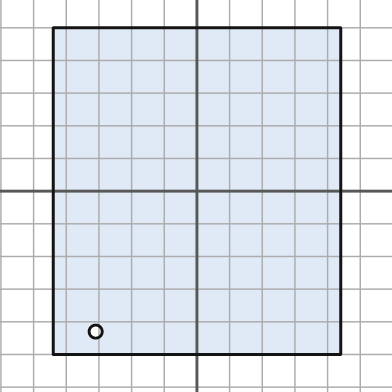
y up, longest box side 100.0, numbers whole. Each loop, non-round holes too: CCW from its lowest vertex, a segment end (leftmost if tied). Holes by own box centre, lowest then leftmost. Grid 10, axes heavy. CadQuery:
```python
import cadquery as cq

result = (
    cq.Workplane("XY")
    .moveTo(-44.0, -50.0)
    .lineTo(44.0, -50.0)
    .lineTo(44.0, 50.0)
    .lineTo(-44.0, 50.0)
    .close()
    .moveTo(-31.0, -43.0)
    .circle(2.0)
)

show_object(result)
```